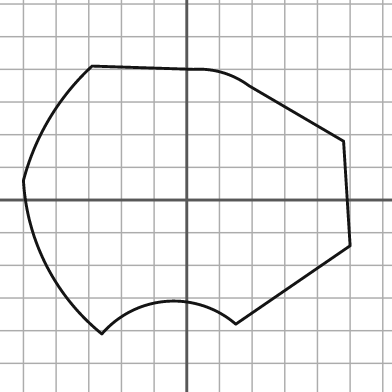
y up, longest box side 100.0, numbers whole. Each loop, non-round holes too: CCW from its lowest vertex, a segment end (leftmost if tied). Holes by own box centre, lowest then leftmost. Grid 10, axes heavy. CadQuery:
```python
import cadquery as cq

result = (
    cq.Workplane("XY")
    .moveTo(-26.0, -41.0)
    .threePointArc((-6.0, -31.0), (15.0, -38.0))
    .lineTo(50.0, -14.0)
    .lineTo(48.0, 18.0)
    .lineTo(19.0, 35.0)
    .threePointArc((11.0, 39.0), (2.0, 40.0))
    .lineTo(-29.0, 41.0)
    .threePointArc((-42.0, 25.0), (-50.0, 6.0))
    .threePointArc((-43.0, -20.0), (-26.0, -41.0))
    .close()
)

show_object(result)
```